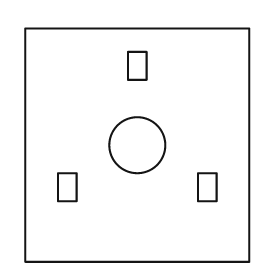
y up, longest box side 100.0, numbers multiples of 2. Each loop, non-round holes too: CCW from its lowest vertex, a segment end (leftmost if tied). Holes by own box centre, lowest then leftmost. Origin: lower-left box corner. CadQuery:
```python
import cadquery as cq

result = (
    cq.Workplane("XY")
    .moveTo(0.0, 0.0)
    .lineTo(96.0, 0.0)
    .lineTo(96.0, 100.0)
    .lineTo(0.0, 100.0)
    .close()
    .moveTo(14.0, 26.0)
    .lineTo(22.0, 26.0)
    .lineTo(22.0, 38.0)
    .lineTo(14.0, 38.0)
    .close()
    .moveTo(74.0, 26.0)
    .lineTo(82.0, 26.0)
    .lineTo(82.0, 38.0)
    .lineTo(74.0, 38.0)
    .close()
    .moveTo(48.0, 50.0)
    .circle(12.0)
    .moveTo(44.0, 78.0)
    .lineTo(52.0, 78.0)
    .lineTo(52.0, 90.0)
    .lineTo(44.0, 90.0)
    .close()
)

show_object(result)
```